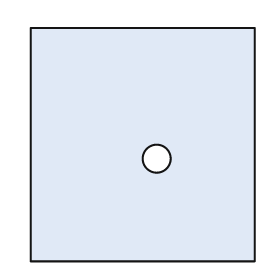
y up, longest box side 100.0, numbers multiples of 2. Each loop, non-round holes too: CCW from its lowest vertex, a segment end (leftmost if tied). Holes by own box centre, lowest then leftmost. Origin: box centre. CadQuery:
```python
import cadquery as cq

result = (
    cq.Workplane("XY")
    .moveTo(-48.0, -50.0)
    .lineTo(48.0, -50.0)
    .lineTo(48.0, 50.0)
    .lineTo(-48.0, 50.0)
    .close()
    .moveTo(6.0, -6.0)
    .circle(6.0)
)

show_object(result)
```